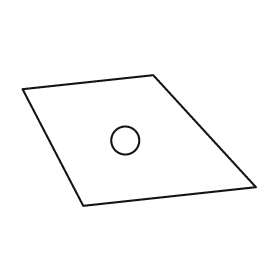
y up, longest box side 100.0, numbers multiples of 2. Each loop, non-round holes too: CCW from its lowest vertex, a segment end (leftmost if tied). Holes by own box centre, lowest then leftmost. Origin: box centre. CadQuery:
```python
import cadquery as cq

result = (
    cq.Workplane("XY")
    .moveTo(-24.0, -28.0)
    .lineTo(50.0, -20.0)
    .lineTo(6.0, 28.0)
    .lineTo(-50.0, 22.0)
    .close()
    .moveTo(-6.0, 0.0)
    .circle(6.0)
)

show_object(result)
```